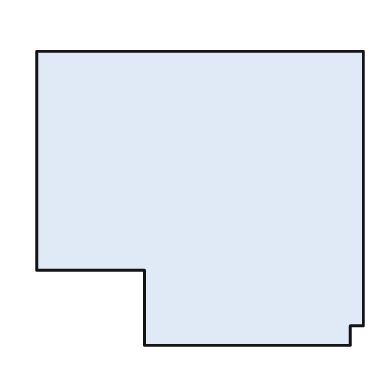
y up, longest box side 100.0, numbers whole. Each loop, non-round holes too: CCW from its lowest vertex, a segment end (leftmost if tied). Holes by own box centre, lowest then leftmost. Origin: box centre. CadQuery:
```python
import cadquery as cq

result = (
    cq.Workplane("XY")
    .moveTo(-17.0, -45.0)
    .lineTo(46.0, -45.0)
    .lineTo(46.0, -39.0)
    .lineTo(50.0, -39.0)
    .lineTo(50.0, 45.0)
    .lineTo(-50.0, 45.0)
    .lineTo(-50.0, -22.0)
    .lineTo(-17.0, -22.0)
    .close()
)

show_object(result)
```